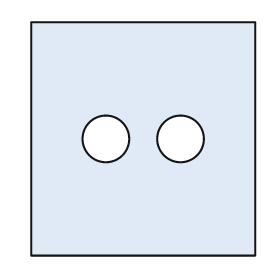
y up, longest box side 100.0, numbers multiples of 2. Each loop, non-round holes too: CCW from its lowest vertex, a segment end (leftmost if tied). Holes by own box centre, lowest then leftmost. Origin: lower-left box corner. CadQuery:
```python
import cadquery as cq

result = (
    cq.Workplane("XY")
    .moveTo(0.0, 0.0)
    .lineTo(96.0, 0.0)
    .lineTo(96.0, 100.0)
    .lineTo(0.0, 100.0)
    .close()
    .moveTo(32.0, 50.0)
    .circle(10.0)
    .moveTo(64.0, 50.0)
    .circle(10.0)
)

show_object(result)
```